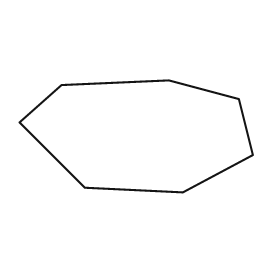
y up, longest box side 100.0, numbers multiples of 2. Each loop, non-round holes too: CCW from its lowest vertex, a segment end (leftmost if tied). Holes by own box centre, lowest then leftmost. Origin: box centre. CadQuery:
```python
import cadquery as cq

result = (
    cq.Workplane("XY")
    .moveTo(20.0, -24.0)
    .lineTo(50.0, -8.0)
    .lineTo(44.0, 16.0)
    .lineTo(14.0, 24.0)
    .lineTo(-32.0, 22.0)
    .lineTo(-50.0, 6.0)
    .lineTo(-22.0, -22.0)
    .close()
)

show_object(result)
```